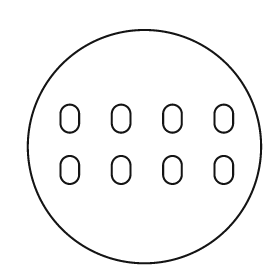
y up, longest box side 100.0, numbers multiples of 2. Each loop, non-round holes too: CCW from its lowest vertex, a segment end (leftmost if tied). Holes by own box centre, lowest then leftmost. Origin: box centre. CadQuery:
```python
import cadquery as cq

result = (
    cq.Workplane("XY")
    .moveTo(0.0, 0.0)
    .circle(50.0)
    .moveTo(-36.0, -12.0)
    .threePointArc((-32.0, -16.0), (-28.0, -12.0))
    .lineTo(-28.0, -8.0)
    .threePointArc((-32.0, -4.0), (-36.0, -8.0))
    .close()
    .moveTo(-14.0, -12.0)
    .threePointArc((-10.0, -16.0), (-6.0, -12.0))
    .lineTo(-6.0, -8.0)
    .threePointArc((-10.0, -4.0), (-14.0, -8.0))
    .close()
    .moveTo(8.0, -12.0)
    .threePointArc((12.0, -16.0), (16.0, -12.0))
    .lineTo(16.0, -8.0)
    .threePointArc((12.0, -4.0), (8.0, -8.0))
    .close()
    .moveTo(30.0, -12.0)
    .threePointArc((34.0, -16.0), (38.0, -12.0))
    .lineTo(38.0, -8.0)
    .threePointArc((34.0, -4.0), (30.0, -8.0))
    .close()
    .moveTo(-36.0, 10.0)
    .threePointArc((-32.0, 6.0), (-28.0, 10.0))
    .lineTo(-28.0, 14.0)
    .threePointArc((-32.0, 18.0), (-36.0, 14.0))
    .close()
    .moveTo(-14.0, 10.0)
    .threePointArc((-10.0, 6.0), (-6.0, 10.0))
    .lineTo(-6.0, 14.0)
    .threePointArc((-10.0, 18.0), (-14.0, 14.0))
    .close()
    .moveTo(8.0, 10.0)
    .threePointArc((12.0, 6.0), (16.0, 10.0))
    .lineTo(16.0, 14.0)
    .threePointArc((12.0, 18.0), (8.0, 14.0))
    .close()
    .moveTo(30.0, 10.0)
    .threePointArc((34.0, 6.0), (38.0, 10.0))
    .lineTo(38.0, 14.0)
    .threePointArc((34.0, 18.0), (30.0, 14.0))
    .close()
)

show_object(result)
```